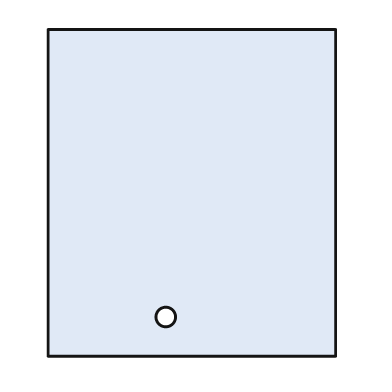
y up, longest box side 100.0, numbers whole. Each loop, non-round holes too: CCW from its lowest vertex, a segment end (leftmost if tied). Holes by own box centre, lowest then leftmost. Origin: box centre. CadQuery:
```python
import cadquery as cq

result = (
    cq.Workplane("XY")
    .moveTo(-44.0, -50.0)
    .lineTo(44.0, -50.0)
    .lineTo(44.0, 50.0)
    .lineTo(-44.0, 50.0)
    .close()
    .moveTo(-8.0, -38.0)
    .circle(3.0)
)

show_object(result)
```